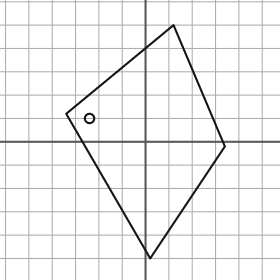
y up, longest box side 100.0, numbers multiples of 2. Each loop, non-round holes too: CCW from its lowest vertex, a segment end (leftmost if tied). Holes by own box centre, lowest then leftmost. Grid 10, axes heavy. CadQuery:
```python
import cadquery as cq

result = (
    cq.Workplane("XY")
    .moveTo(2.0, -50.0)
    .lineTo(34.0, -2.0)
    .lineTo(12.0, 50.0)
    .lineTo(-34.0, 12.0)
    .close()
    .moveTo(-24.0, 10.0)
    .circle(2.0)
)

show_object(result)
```